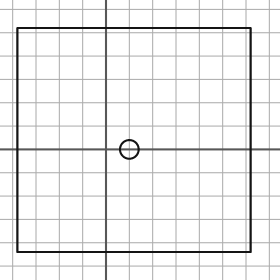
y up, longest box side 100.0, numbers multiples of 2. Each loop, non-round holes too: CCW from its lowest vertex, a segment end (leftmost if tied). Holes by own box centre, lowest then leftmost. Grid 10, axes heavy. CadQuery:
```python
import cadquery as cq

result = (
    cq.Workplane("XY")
    .moveTo(-38.0, -44.0)
    .lineTo(62.0, -44.0)
    .lineTo(62.0, 52.0)
    .lineTo(-38.0, 52.0)
    .close()
    .moveTo(10.0, 0.0)
    .circle(4.0)
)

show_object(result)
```